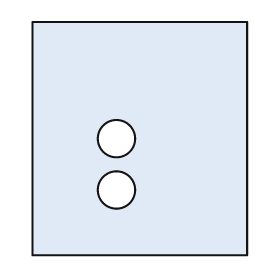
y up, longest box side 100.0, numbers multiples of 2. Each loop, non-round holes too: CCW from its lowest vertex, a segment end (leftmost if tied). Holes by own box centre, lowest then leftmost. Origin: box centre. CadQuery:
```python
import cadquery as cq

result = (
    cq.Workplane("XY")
    .moveTo(-46.0, -50.0)
    .lineTo(46.0, -50.0)
    .lineTo(46.0, 50.0)
    .lineTo(-46.0, 50.0)
    .close()
    .moveTo(-10.0, -22.0)
    .circle(8.0)
    .moveTo(-10.0, 0.0)
    .circle(8.0)
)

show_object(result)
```